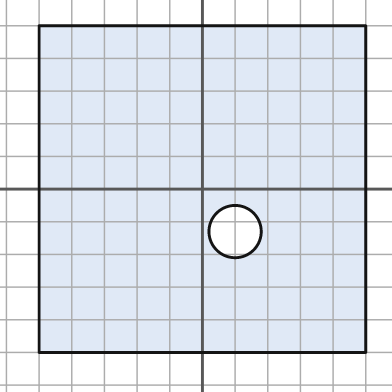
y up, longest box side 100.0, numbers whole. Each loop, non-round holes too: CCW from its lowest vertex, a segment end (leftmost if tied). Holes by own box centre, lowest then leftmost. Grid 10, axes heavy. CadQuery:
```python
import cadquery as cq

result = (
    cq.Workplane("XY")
    .moveTo(-50.0, -50.0)
    .lineTo(50.0, -50.0)
    .lineTo(50.0, 50.0)
    .lineTo(-50.0, 50.0)
    .close()
    .moveTo(10.0, -13.0)
    .circle(8.0)
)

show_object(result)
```